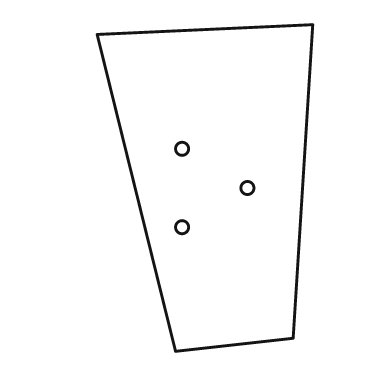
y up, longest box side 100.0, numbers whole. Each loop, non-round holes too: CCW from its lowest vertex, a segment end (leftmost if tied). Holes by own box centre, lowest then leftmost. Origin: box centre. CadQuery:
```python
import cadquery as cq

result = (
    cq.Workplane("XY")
    .moveTo(-9.0, -50.0)
    .lineTo(27.0, -46.0)
    .lineTo(33.0, 50.0)
    .lineTo(-33.0, 47.0)
    .close()
    .moveTo(-7.0, -12.0)
    .circle(2.0)
    .moveTo(13.0, 0.0)
    .circle(2.0)
    .moveTo(-7.0, 12.0)
    .circle(2.0)
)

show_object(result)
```